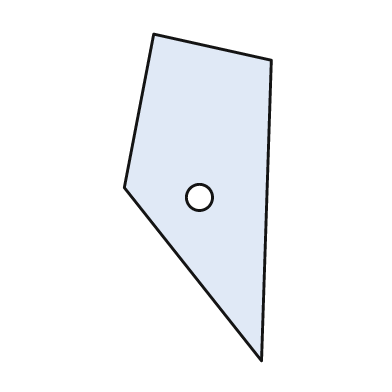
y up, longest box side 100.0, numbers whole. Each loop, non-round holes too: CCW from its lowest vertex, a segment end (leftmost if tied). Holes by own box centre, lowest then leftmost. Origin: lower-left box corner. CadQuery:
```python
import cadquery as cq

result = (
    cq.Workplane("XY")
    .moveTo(42.0, 0.0)
    .lineTo(45.0, 92.0)
    .lineTo(9.0, 100.0)
    .lineTo(0.0, 53.0)
    .close()
    .moveTo(23.0, 50.0)
    .circle(4.0)
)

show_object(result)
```